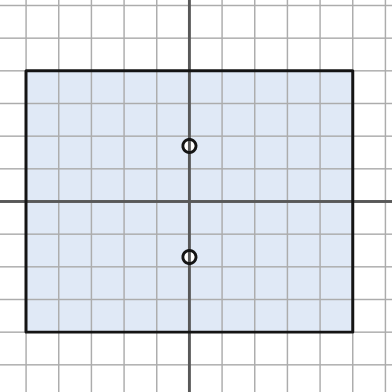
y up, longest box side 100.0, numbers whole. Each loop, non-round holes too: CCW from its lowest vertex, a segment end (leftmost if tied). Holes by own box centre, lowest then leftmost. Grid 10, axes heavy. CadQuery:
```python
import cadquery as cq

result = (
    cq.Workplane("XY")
    .moveTo(-50.0, -40.0)
    .lineTo(50.0, -40.0)
    .lineTo(50.0, 40.0)
    .lineTo(-50.0, 40.0)
    .close()
    .moveTo(0.0, -17.0)
    .circle(2.0)
    .moveTo(0.0, 17.0)
    .circle(2.0)
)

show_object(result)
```